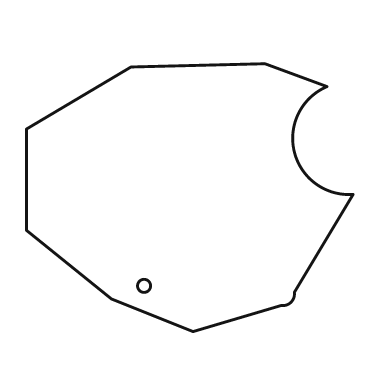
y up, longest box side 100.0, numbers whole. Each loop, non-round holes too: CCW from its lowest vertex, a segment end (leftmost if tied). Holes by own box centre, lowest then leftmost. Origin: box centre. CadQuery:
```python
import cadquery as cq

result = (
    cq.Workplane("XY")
    .moveTo(1.0, -41.0)
    .lineTo(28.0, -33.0)
    .threePointArc((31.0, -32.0), (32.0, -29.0))
    .lineTo(50.0, 1.0)
    .threePointArc((32.0, 14.0), (42.0, 34.0))
    .lineTo(23.0, 41.0)
    .lineTo(-18.0, 40.0)
    .lineTo(-50.0, 21.0)
    .lineTo(-50.0, -10.0)
    .lineTo(-24.0, -31.0)
    .close()
    .moveTo(-14.0, -27.0)
    .circle(2.0)
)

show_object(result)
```